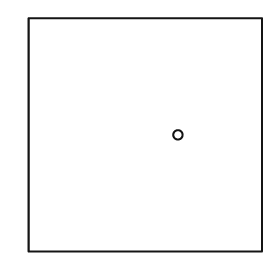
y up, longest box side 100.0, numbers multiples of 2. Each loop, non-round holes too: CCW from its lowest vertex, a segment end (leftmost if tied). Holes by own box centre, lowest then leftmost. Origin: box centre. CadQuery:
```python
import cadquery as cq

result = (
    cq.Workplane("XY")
    .moveTo(-50.0, -50.0)
    .lineTo(50.0, -50.0)
    .lineTo(50.0, 50.0)
    .lineTo(-50.0, 50.0)
    .close()
    .moveTo(14.0, 0.0)
    .circle(2.0)
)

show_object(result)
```